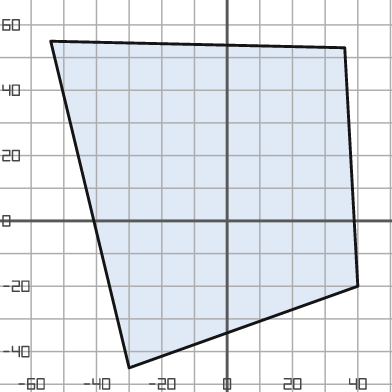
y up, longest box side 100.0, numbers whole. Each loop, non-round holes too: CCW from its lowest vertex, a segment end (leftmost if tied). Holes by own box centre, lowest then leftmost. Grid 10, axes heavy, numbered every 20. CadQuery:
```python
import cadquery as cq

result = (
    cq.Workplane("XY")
    .moveTo(-30.0, -45.0)
    .lineTo(40.0, -20.0)
    .lineTo(36.0, 53.0)
    .lineTo(-54.0, 55.0)
    .close()
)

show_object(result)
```